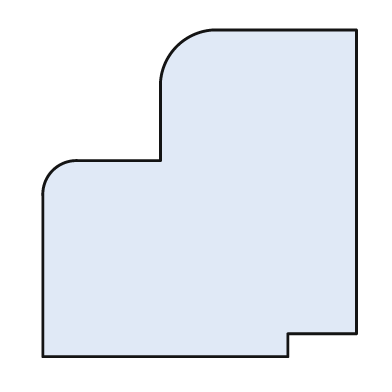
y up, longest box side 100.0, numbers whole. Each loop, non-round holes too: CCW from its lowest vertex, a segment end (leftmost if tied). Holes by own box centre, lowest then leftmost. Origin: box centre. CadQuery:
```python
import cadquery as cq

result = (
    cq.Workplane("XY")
    .moveTo(-48.0, -50.0)
    .lineTo(27.0, -50.0)
    .lineTo(27.0, -43.0)
    .lineTo(48.0, -43.0)
    .lineTo(48.0, 50.0)
    .lineTo(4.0, 50.0)
    .threePointArc((-7.0, 45.0), (-12.0, 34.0))
    .lineTo(-12.0, 10.0)
    .lineTo(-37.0, 10.0)
    .threePointArc((-45.0, 7.0), (-48.0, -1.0))
    .close()
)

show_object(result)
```